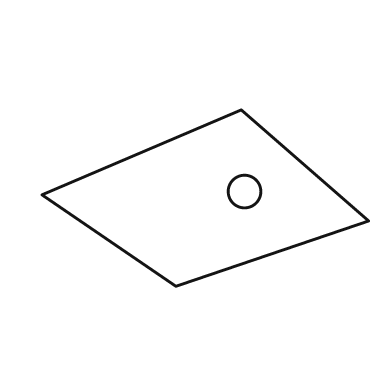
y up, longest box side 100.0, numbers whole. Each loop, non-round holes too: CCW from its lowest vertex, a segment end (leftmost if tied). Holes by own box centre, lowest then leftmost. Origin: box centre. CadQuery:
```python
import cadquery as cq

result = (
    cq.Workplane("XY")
    .moveTo(-9.0, -27.0)
    .lineTo(50.0, -7.0)
    .lineTo(11.0, 27.0)
    .lineTo(-50.0, 1.0)
    .close()
    .moveTo(12.0, 2.0)
    .circle(5.0)
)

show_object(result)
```